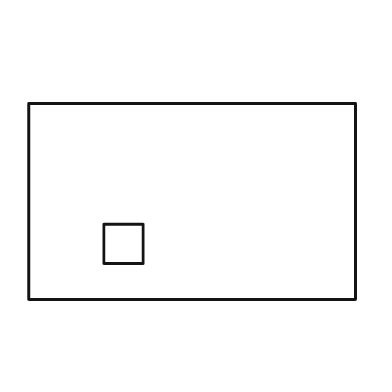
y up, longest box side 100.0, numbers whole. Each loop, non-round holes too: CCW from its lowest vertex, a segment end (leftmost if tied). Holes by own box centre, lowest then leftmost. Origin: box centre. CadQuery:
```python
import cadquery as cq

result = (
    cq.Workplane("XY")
    .moveTo(-50.0, -30.0)
    .lineTo(50.0, -30.0)
    .lineTo(50.0, 30.0)
    .lineTo(-50.0, 30.0)
    .close()
    .moveTo(-27.0, -19.0)
    .lineTo(-15.0, -19.0)
    .lineTo(-15.0, -7.0)
    .lineTo(-27.0, -7.0)
    .close()
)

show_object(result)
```